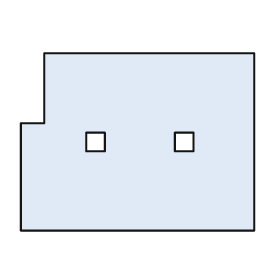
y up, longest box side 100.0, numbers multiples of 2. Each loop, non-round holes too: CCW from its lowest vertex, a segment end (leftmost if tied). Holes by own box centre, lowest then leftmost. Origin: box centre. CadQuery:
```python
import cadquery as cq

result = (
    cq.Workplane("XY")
    .moveTo(-50.0, -38.0)
    .lineTo(50.0, -38.0)
    .lineTo(50.0, 38.0)
    .lineTo(-40.0, 38.0)
    .lineTo(-40.0, 8.0)
    .lineTo(-50.0, 8.0)
    .close()
    .moveTo(-22.0, -4.0)
    .lineTo(-14.0, -4.0)
    .lineTo(-14.0, 4.0)
    .lineTo(-22.0, 4.0)
    .close()
    .moveTo(16.0, -4.0)
    .lineTo(24.0, -4.0)
    .lineTo(24.0, 4.0)
    .lineTo(16.0, 4.0)
    .close()
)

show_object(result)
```